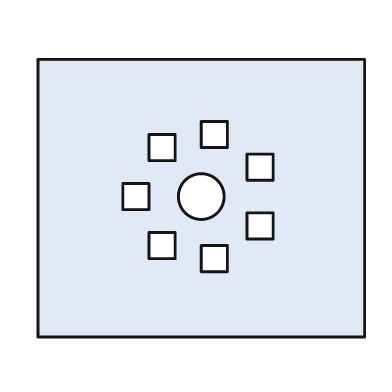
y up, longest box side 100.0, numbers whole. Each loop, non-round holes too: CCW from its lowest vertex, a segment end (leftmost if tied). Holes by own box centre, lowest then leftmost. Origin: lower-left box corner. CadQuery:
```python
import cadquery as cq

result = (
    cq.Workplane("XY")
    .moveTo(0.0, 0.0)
    .lineTo(100.0, 0.0)
    .lineTo(100.0, 85.0)
    .lineTo(0.0, 85.0)
    .close()
    .moveTo(50.0, 20.0)
    .lineTo(58.0, 20.0)
    .lineTo(58.0, 28.0)
    .lineTo(50.0, 28.0)
    .close()
    .moveTo(34.0, 24.0)
    .lineTo(42.0, 24.0)
    .lineTo(42.0, 32.0)
    .lineTo(34.0, 32.0)
    .close()
    .moveTo(64.0, 30.0)
    .lineTo(72.0, 30.0)
    .lineTo(72.0, 38.0)
    .lineTo(64.0, 38.0)
    .close()
    .moveTo(26.0, 39.0)
    .lineTo(34.0, 39.0)
    .lineTo(34.0, 47.0)
    .lineTo(26.0, 47.0)
    .close()
    .moveTo(50.0, 43.0)
    .circle(7.0)
    .moveTo(64.0, 48.0)
    .lineTo(72.0, 48.0)
    .lineTo(72.0, 56.0)
    .lineTo(64.0, 56.0)
    .close()
    .moveTo(34.0, 54.0)
    .lineTo(42.0, 54.0)
    .lineTo(42.0, 62.0)
    .lineTo(34.0, 62.0)
    .close()
    .moveTo(50.0, 58.0)
    .lineTo(58.0, 58.0)
    .lineTo(58.0, 66.0)
    .lineTo(50.0, 66.0)
    .close()
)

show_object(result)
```